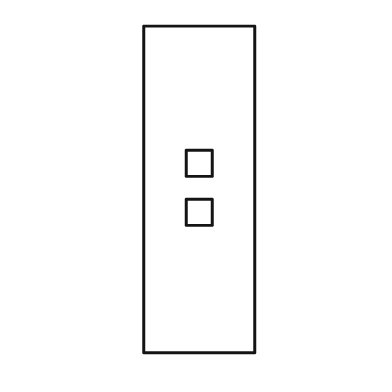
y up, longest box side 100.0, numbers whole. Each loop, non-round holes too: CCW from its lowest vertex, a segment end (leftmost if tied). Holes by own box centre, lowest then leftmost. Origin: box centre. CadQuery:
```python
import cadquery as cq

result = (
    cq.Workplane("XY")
    .moveTo(-17.0, -50.0)
    .lineTo(17.0, -50.0)
    .lineTo(17.0, 50.0)
    .lineTo(-17.0, 50.0)
    .close()
    .moveTo(-4.0, -11.0)
    .lineTo(4.0, -11.0)
    .lineTo(4.0, -3.0)
    .lineTo(-4.0, -3.0)
    .close()
    .moveTo(-4.0, 4.0)
    .lineTo(4.0, 4.0)
    .lineTo(4.0, 12.0)
    .lineTo(-4.0, 12.0)
    .close()
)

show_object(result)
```